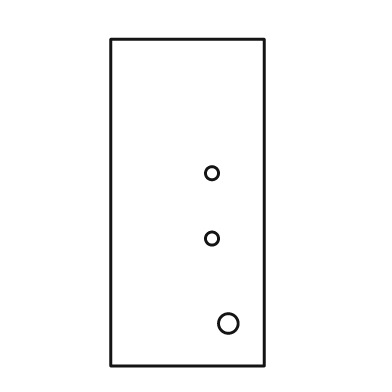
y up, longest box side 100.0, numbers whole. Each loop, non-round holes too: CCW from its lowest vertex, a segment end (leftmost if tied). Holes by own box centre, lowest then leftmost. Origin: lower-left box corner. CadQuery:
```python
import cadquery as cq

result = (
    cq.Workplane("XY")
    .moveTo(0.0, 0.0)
    .lineTo(47.0, 0.0)
    .lineTo(47.0, 100.0)
    .lineTo(0.0, 100.0)
    .close()
    .moveTo(36.0, 13.0)
    .circle(3.0)
    .moveTo(31.0, 39.0)
    .circle(2.0)
    .moveTo(31.0, 59.0)
    .circle(2.0)
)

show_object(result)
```